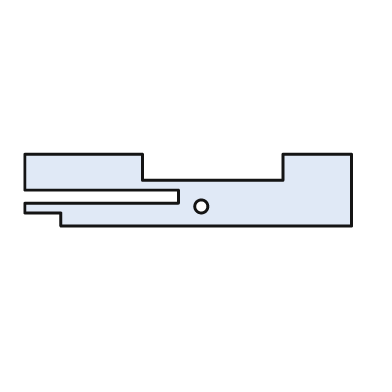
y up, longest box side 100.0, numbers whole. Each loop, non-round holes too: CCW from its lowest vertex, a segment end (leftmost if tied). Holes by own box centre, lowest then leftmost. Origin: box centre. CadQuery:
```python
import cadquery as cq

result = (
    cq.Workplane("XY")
    .moveTo(-39.0, -11.0)
    .lineTo(50.0, -11.0)
    .lineTo(50.0, 11.0)
    .lineTo(29.0, 11.0)
    .lineTo(29.0, 3.0)
    .lineTo(-14.0, 3.0)
    .lineTo(-14.0, 11.0)
    .lineTo(-50.0, 11.0)
    .lineTo(-50.0, 0.0)
    .lineTo(-3.0, 0.0)
    .lineTo(-3.0, -4.0)
    .lineTo(-50.0, -4.0)
    .lineTo(-50.0, -7.0)
    .lineTo(-39.0, -7.0)
    .close()
    .moveTo(4.0, -5.0)
    .circle(2.0)
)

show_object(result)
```